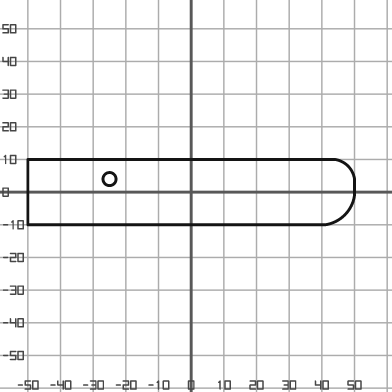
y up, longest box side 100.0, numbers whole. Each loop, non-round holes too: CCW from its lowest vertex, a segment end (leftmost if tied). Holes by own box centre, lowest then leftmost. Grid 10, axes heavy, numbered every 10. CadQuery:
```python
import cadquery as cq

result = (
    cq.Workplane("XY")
    .moveTo(-50.0, -10.0)
    .lineTo(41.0, -10.0)
    .threePointArc((47.0, -7.0), (50.0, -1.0))
    .lineTo(50.0, 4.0)
    .threePointArc((48.0, 8.0), (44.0, 10.0))
    .lineTo(-50.0, 10.0)
    .close()
    .moveTo(-25.0, 4.0)
    .circle(2.0)
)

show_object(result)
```